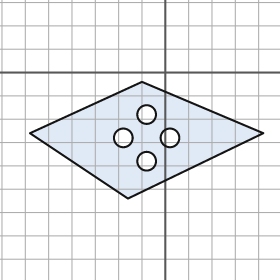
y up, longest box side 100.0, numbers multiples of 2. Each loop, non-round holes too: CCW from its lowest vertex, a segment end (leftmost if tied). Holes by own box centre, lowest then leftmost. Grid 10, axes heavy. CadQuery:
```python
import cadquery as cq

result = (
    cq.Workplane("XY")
    .moveTo(-16.0, -54.0)
    .lineTo(42.0, -26.0)
    .lineTo(-10.0, -4.0)
    .lineTo(-58.0, -26.0)
    .close()
    .moveTo(-8.0, -38.0)
    .circle(4.0)
    .moveTo(-18.0, -28.0)
    .circle(4.0)
    .moveTo(2.0, -28.0)
    .circle(4.0)
    .moveTo(-8.0, -18.0)
    .circle(4.0)
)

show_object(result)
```